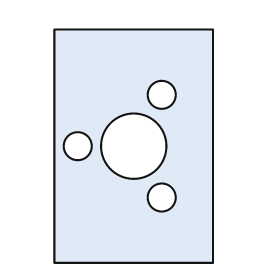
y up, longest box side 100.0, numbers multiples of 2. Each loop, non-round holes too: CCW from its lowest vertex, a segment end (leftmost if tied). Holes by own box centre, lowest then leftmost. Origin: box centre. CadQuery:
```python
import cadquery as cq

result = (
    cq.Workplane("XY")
    .moveTo(-34.0, -50.0)
    .lineTo(34.0, -50.0)
    .lineTo(34.0, 50.0)
    .lineTo(-34.0, 50.0)
    .close()
    .moveTo(12.0, -22.0)
    .circle(6.0)
    .moveTo(-24.0, 0.0)
    .circle(6.0)
    .moveTo(0.0, 0.0)
    .circle(14.0)
    .moveTo(12.0, 22.0)
    .circle(6.0)
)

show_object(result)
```